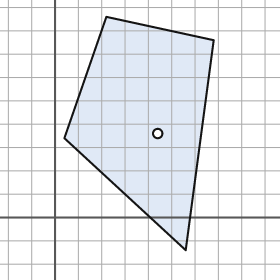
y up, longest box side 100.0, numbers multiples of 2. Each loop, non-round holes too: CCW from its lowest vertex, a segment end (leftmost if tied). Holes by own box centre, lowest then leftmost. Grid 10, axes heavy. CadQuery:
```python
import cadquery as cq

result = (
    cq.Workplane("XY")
    .moveTo(56.0, -14.0)
    .lineTo(68.0, 76.0)
    .lineTo(22.0, 86.0)
    .lineTo(4.0, 34.0)
    .close()
    .moveTo(44.0, 36.0)
    .circle(2.0)
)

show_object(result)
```